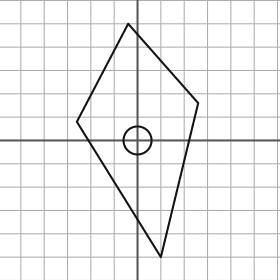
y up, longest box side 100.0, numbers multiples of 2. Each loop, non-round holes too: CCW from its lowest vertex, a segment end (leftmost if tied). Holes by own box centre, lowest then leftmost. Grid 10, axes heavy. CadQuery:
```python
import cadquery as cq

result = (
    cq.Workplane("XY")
    .moveTo(10.0, -50.0)
    .lineTo(26.0, 16.0)
    .lineTo(-4.0, 50.0)
    .lineTo(-26.0, 8.0)
    .close()
    .moveTo(0.0, 0.0)
    .circle(6.0)
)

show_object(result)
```